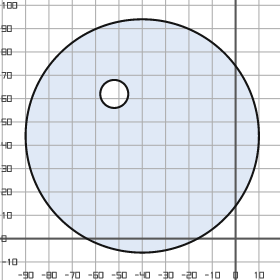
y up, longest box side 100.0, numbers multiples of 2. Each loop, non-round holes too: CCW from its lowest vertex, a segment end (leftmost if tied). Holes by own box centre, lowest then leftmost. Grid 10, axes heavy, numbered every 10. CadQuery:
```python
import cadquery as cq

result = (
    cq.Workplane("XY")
    .moveTo(-40.0, 44.0)
    .circle(50.0)
    .moveTo(-52.0, 62.0)
    .circle(6.0)
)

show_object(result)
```